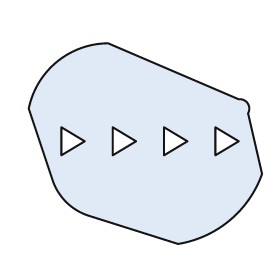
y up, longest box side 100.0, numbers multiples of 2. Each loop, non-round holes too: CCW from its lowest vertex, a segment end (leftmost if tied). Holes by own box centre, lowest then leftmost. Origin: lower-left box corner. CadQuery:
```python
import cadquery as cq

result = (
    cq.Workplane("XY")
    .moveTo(64.0, 0.0)
    .threePointArc((86.0, 10.0), (100.0, 30.0))
    .lineTo(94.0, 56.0)
    .threePointArc((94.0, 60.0), (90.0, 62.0))
    .lineTo(34.0, 86.0)
    .threePointArc((12.0, 78.0), (0.0, 58.0))
    .lineTo(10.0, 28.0)
    .threePointArc((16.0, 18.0), (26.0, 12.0))
    .close()
    .moveTo(14.0, 38.0)
    .lineTo(24.0, 44.0)
    .lineTo(14.0, 50.0)
    .close()
    .moveTo(36.0, 38.0)
    .lineTo(46.0, 44.0)
    .lineTo(36.0, 50.0)
    .close()
    .moveTo(58.0, 38.0)
    .lineTo(68.0, 44.0)
    .lineTo(58.0, 50.0)
    .close()
    .moveTo(80.0, 38.0)
    .lineTo(90.0, 44.0)
    .lineTo(80.0, 50.0)
    .close()
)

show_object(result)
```